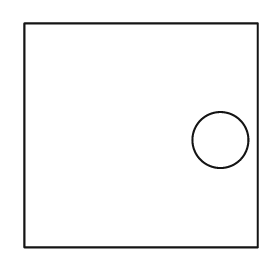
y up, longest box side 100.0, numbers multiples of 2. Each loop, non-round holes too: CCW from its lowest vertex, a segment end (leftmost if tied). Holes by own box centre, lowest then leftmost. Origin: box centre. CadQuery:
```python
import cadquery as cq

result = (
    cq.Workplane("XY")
    .moveTo(-50.0, -48.0)
    .lineTo(50.0, -48.0)
    .lineTo(50.0, 48.0)
    .lineTo(-50.0, 48.0)
    .close()
    .moveTo(34.0, -2.0)
    .circle(12.0)
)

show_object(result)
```